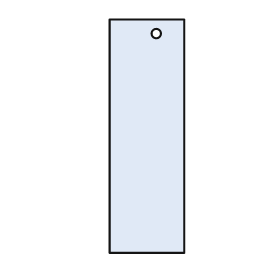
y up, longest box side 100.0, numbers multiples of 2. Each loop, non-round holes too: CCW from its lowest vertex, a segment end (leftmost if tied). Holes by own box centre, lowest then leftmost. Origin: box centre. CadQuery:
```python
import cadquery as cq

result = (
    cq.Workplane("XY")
    .moveTo(-16.0, -50.0)
    .lineTo(16.0, -50.0)
    .lineTo(16.0, 50.0)
    .lineTo(-16.0, 50.0)
    .close()
    .moveTo(4.0, 44.0)
    .circle(2.0)
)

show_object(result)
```